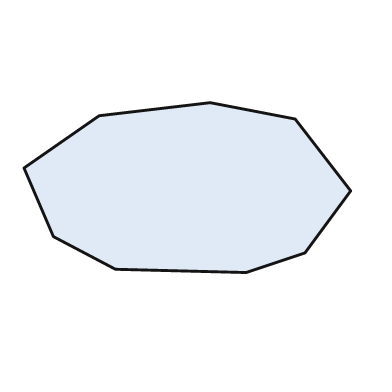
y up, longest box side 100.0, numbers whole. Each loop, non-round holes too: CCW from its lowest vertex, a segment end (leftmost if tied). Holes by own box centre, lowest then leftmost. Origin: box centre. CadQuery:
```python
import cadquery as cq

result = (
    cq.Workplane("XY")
    .moveTo(18.0, -26.0)
    .lineTo(36.0, -20.0)
    .lineTo(50.0, -1.0)
    .lineTo(33.0, 21.0)
    .lineTo(7.0, 26.0)
    .lineTo(-27.0, 22.0)
    .lineTo(-50.0, 6.0)
    .lineTo(-41.0, -15.0)
    .lineTo(-22.0, -25.0)
    .close()
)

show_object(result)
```